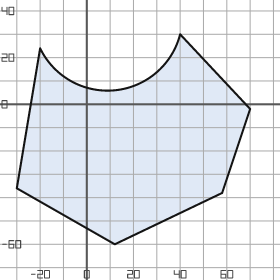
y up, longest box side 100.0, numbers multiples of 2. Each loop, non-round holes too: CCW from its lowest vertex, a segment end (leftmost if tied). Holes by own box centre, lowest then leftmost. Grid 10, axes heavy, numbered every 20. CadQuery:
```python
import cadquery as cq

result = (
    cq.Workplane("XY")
    .moveTo(12.0, -60.0)
    .lineTo(58.0, -38.0)
    .lineTo(70.0, -2.0)
    .lineTo(40.0, 30.0)
    .threePointArc((12.0, 6.0), (-20.0, 24.0))
    .lineTo(-30.0, -36.0)
    .close()
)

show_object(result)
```